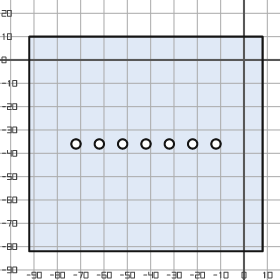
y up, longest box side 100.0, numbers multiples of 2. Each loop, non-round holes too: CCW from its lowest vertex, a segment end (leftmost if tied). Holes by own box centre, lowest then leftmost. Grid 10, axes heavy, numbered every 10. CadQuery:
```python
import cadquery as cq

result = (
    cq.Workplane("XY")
    .moveTo(-92.0, -82.0)
    .lineTo(8.0, -82.0)
    .lineTo(8.0, 10.0)
    .lineTo(-92.0, 10.0)
    .close()
    .moveTo(-72.0, -36.0)
    .circle(2.0)
    .moveTo(-62.0, -36.0)
    .circle(2.0)
    .moveTo(-52.0, -36.0)
    .circle(2.0)
    .moveTo(-42.0, -36.0)
    .circle(2.0)
    .moveTo(-32.0, -36.0)
    .circle(2.0)
    .moveTo(-22.0, -36.0)
    .circle(2.0)
    .moveTo(-12.0, -36.0)
    .circle(2.0)
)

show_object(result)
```